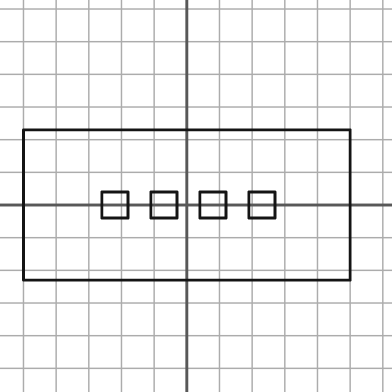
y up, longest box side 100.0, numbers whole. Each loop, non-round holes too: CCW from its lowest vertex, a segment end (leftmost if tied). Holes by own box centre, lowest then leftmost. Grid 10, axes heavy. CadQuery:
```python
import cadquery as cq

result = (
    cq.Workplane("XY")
    .moveTo(-50.0, -23.0)
    .lineTo(50.0, -23.0)
    .lineTo(50.0, 23.0)
    .lineTo(-50.0, 23.0)
    .close()
    .moveTo(-26.0, -4.0)
    .lineTo(-18.0, -4.0)
    .lineTo(-18.0, 4.0)
    .lineTo(-26.0, 4.0)
    .close()
    .moveTo(-11.0, -4.0)
    .lineTo(-3.0, -4.0)
    .lineTo(-3.0, 4.0)
    .lineTo(-11.0, 4.0)
    .close()
    .moveTo(4.0, -4.0)
    .lineTo(12.0, -4.0)
    .lineTo(12.0, 4.0)
    .lineTo(4.0, 4.0)
    .close()
    .moveTo(19.0, -4.0)
    .lineTo(27.0, -4.0)
    .lineTo(27.0, 4.0)
    .lineTo(19.0, 4.0)
    .close()
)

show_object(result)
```